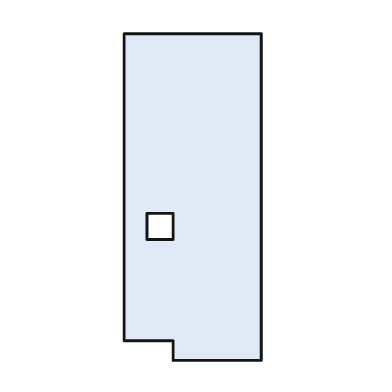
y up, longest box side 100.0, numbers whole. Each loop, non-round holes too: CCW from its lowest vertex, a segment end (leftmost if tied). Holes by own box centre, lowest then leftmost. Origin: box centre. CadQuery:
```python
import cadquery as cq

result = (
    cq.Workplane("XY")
    .moveTo(-6.0, -50.0)
    .lineTo(21.0, -50.0)
    .lineTo(21.0, 50.0)
    .lineTo(-21.0, 50.0)
    .lineTo(-21.0, -44.0)
    .lineTo(-6.0, -44.0)
    .close()
    .moveTo(-14.0, -13.0)
    .lineTo(-6.0, -13.0)
    .lineTo(-6.0, -5.0)
    .lineTo(-14.0, -5.0)
    .close()
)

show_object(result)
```